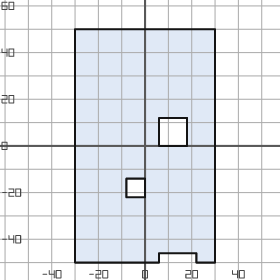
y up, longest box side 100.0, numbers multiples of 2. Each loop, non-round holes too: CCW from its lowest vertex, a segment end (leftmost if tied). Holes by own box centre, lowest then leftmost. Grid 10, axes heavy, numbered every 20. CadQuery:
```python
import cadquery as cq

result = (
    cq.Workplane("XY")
    .moveTo(-30.0, -50.0)
    .lineTo(6.0, -50.0)
    .lineTo(6.0, -46.0)
    .lineTo(22.0, -46.0)
    .lineTo(22.0, -50.0)
    .lineTo(30.0, -50.0)
    .lineTo(30.0, 50.0)
    .lineTo(-30.0, 50.0)
    .close()
    .moveTo(-8.0, -22.0)
    .lineTo(0.0, -22.0)
    .lineTo(0.0, -14.0)
    .lineTo(-8.0, -14.0)
    .close()
    .moveTo(6.0, 0.0)
    .lineTo(18.0, 0.0)
    .lineTo(18.0, 12.0)
    .lineTo(6.0, 12.0)
    .close()
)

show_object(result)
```